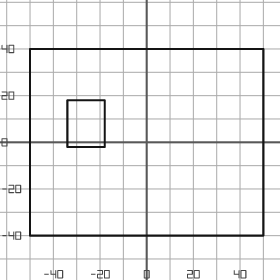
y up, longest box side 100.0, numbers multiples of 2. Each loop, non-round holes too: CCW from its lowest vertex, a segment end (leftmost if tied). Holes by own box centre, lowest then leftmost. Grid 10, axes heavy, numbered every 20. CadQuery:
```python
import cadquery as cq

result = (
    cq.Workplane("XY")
    .moveTo(-50.0, -40.0)
    .lineTo(50.0, -40.0)
    .lineTo(50.0, 40.0)
    .lineTo(-50.0, 40.0)
    .close()
    .moveTo(-34.0, -2.0)
    .lineTo(-18.0, -2.0)
    .lineTo(-18.0, 18.0)
    .lineTo(-34.0, 18.0)
    .close()
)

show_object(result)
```